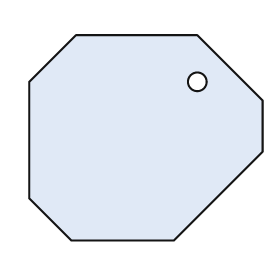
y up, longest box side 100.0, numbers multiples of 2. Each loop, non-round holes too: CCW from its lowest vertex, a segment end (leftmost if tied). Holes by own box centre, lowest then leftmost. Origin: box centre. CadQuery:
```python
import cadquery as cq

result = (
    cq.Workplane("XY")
    .moveTo(-32.0, -44.0)
    .lineTo(12.0, -44.0)
    .lineTo(50.0, -6.0)
    .lineTo(50.0, 16.0)
    .lineTo(22.0, 44.0)
    .lineTo(-30.0, 44.0)
    .lineTo(-50.0, 24.0)
    .lineTo(-50.0, -26.0)
    .close()
    .moveTo(22.0, 24.0)
    .circle(4.0)
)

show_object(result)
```